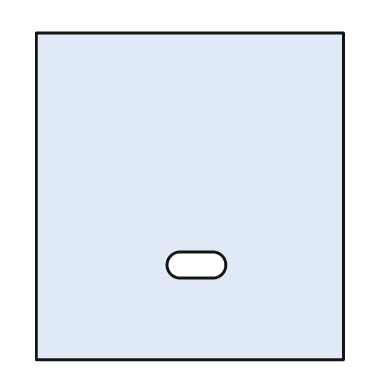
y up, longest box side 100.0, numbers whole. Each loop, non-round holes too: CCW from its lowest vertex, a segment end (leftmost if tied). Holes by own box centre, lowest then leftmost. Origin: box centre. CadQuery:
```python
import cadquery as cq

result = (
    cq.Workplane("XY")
    .moveTo(-47.0, -50.0)
    .lineTo(47.0, -50.0)
    .lineTo(47.0, 50.0)
    .lineTo(-47.0, 50.0)
    .close()
    .moveTo(-3.0, -25.0)
    .lineTo(7.0, -25.0)
    .threePointArc((11.0, -21.0), (7.0, -17.0))
    .lineTo(-3.0, -17.0)
    .threePointArc((-7.0, -21.0), (-3.0, -25.0))
    .close()
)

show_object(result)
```